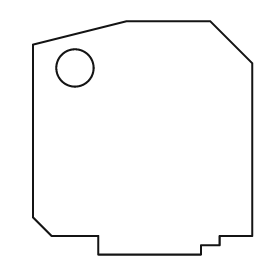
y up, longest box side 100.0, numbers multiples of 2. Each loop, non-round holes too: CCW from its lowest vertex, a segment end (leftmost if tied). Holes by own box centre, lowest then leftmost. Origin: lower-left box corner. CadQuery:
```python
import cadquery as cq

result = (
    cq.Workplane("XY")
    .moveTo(28.0, 0.0)
    .lineTo(72.0, 0.0)
    .lineTo(72.0, 4.0)
    .lineTo(80.0, 4.0)
    .lineTo(80.0, 8.0)
    .lineTo(94.0, 8.0)
    .lineTo(94.0, 82.0)
    .lineTo(76.0, 100.0)
    .lineTo(40.0, 100.0)
    .lineTo(0.0, 90.0)
    .lineTo(0.0, 16.0)
    .lineTo(8.0, 8.0)
    .lineTo(28.0, 8.0)
    .close()
    .moveTo(18.0, 80.0)
    .circle(8.0)
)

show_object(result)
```